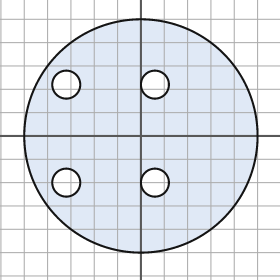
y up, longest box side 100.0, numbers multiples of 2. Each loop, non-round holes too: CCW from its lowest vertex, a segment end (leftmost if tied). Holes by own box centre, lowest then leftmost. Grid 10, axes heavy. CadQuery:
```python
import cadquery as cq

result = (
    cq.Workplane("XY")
    .moveTo(0.0, 0.0)
    .circle(50.0)
    .moveTo(-32.0, -20.0)
    .circle(6.0)
    .moveTo(6.0, -20.0)
    .circle(6.0)
    .moveTo(-32.0, 22.0)
    .circle(6.0)
    .moveTo(6.0, 22.0)
    .circle(6.0)
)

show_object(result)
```